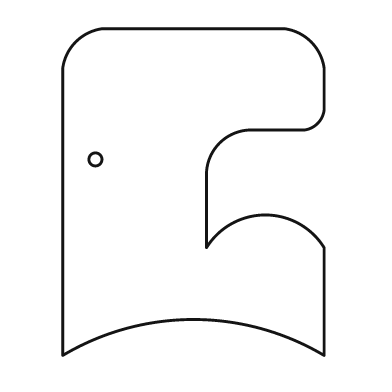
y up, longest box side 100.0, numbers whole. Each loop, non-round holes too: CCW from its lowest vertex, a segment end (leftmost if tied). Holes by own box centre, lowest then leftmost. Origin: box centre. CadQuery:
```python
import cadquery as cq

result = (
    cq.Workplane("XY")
    .moveTo(-40.0, -50.0)
    .threePointArc((0.0, -39.0), (40.0, -50.0))
    .lineTo(40.0, -17.0)
    .threePointArc((22.0, -7.0), (4.0, -17.0))
    .lineTo(4.0, 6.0)
    .threePointArc((8.0, 15.0), (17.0, 19.0))
    .lineTo(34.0, 19.0)
    .threePointArc((38.0, 21.0), (40.0, 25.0))
    .lineTo(40.0, 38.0)
    .threePointArc((36.0, 46.0), (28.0, 50.0))
    .lineTo(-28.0, 50.0)
    .threePointArc((-36.0, 46.0), (-40.0, 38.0))
    .close()
    .moveTo(-30.0, 10.0)
    .circle(2.0)
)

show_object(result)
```